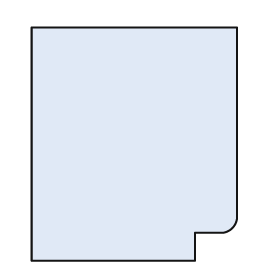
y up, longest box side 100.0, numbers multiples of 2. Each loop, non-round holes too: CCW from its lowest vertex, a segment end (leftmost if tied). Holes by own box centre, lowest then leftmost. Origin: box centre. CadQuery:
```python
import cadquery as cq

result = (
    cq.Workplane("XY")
    .moveTo(-44.0, -50.0)
    .lineTo(26.0, -50.0)
    .lineTo(26.0, -38.0)
    .lineTo(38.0, -38.0)
    .threePointArc((42.0, -36.0), (44.0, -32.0))
    .lineTo(44.0, 50.0)
    .lineTo(-44.0, 50.0)
    .close()
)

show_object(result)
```